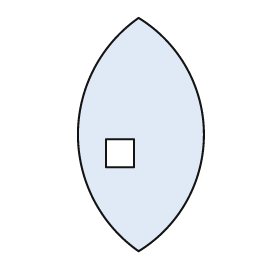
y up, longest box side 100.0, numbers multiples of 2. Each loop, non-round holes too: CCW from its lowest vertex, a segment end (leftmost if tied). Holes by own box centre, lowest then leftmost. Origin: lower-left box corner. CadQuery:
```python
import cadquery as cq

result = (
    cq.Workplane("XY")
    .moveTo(26.0, 0.0)
    .threePointArc((54.0, 50.0), (26.0, 100.0))
    .threePointArc((0.0, 50.0), (26.0, 0.0))
    .close()
    .moveTo(12.0, 36.0)
    .lineTo(24.0, 36.0)
    .lineTo(24.0, 48.0)
    .lineTo(12.0, 48.0)
    .close()
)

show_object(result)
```